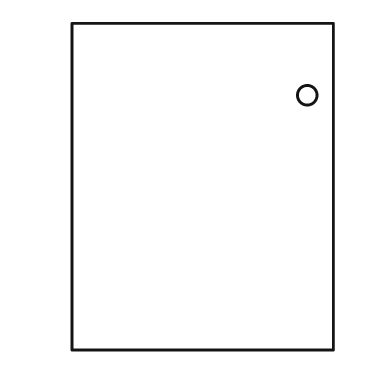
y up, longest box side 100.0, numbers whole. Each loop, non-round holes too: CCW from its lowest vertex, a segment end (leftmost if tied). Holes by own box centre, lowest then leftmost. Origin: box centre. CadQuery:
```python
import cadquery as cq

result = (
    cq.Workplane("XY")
    .moveTo(-40.0, -50.0)
    .lineTo(40.0, -50.0)
    .lineTo(40.0, 50.0)
    .lineTo(-40.0, 50.0)
    .close()
    .moveTo(32.0, 28.0)
    .circle(3.0)
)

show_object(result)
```